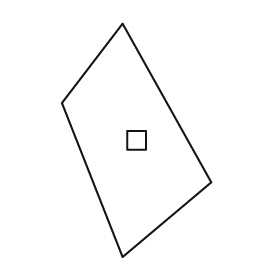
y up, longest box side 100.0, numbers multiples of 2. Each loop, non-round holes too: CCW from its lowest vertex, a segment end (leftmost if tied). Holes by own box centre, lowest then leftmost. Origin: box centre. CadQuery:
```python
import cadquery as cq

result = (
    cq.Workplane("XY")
    .moveTo(-6.0, -50.0)
    .lineTo(32.0, -18.0)
    .lineTo(-6.0, 50.0)
    .lineTo(-32.0, 16.0)
    .close()
    .moveTo(-4.0, -4.0)
    .lineTo(4.0, -4.0)
    .lineTo(4.0, 4.0)
    .lineTo(-4.0, 4.0)
    .close()
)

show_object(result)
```